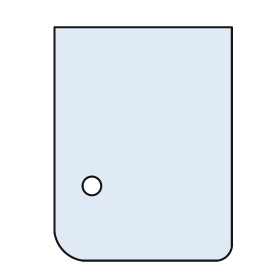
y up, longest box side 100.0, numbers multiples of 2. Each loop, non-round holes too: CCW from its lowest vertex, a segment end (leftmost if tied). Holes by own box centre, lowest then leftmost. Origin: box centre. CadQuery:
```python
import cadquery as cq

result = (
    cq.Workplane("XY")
    .moveTo(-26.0, -50.0)
    .lineTo(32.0, -50.0)
    .threePointArc((36.0, -48.0), (38.0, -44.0))
    .lineTo(38.0, 50.0)
    .lineTo(-38.0, 50.0)
    .lineTo(-38.0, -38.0)
    .threePointArc((-34.0, -46.0), (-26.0, -50.0))
    .close()
    .moveTo(-22.0, -18.0)
    .circle(4.0)
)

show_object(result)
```